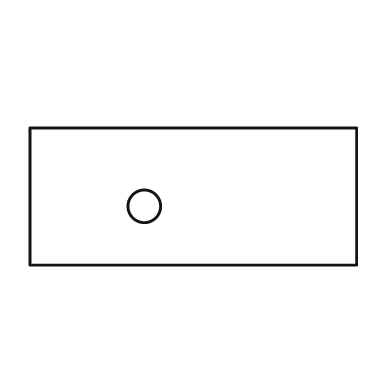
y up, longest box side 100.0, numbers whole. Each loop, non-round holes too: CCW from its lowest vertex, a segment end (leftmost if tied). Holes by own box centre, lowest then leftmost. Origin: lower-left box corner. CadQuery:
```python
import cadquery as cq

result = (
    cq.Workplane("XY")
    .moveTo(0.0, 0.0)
    .lineTo(100.0, 0.0)
    .lineTo(100.0, 42.0)
    .lineTo(0.0, 42.0)
    .close()
    .moveTo(35.0, 18.0)
    .circle(5.0)
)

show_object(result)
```